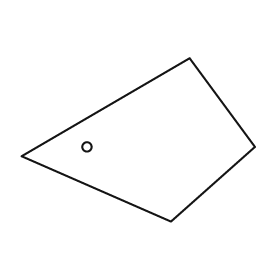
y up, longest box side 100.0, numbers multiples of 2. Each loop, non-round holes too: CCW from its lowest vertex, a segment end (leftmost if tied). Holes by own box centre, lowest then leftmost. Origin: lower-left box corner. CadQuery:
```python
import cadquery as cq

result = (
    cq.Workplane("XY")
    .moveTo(64.0, 0.0)
    .lineTo(100.0, 32.0)
    .lineTo(72.0, 70.0)
    .lineTo(0.0, 28.0)
    .close()
    .moveTo(28.0, 32.0)
    .circle(2.0)
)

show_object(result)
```